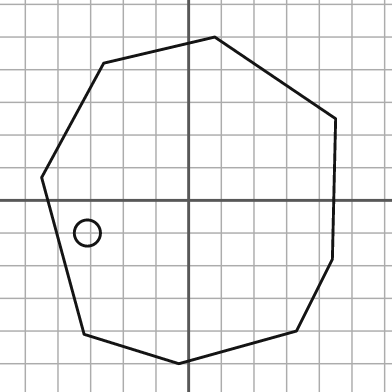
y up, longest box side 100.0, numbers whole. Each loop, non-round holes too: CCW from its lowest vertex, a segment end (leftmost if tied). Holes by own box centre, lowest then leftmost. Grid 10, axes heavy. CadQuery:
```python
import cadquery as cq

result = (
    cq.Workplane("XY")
    .moveTo(-3.0, -50.0)
    .lineTo(33.0, -40.0)
    .lineTo(44.0, -18.0)
    .lineTo(45.0, 25.0)
    .lineTo(8.0, 50.0)
    .lineTo(-26.0, 42.0)
    .lineTo(-45.0, 7.0)
    .lineTo(-32.0, -41.0)
    .close()
    .moveTo(-31.0, -10.0)
    .circle(4.0)
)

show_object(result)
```